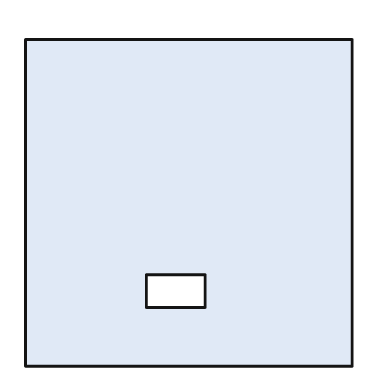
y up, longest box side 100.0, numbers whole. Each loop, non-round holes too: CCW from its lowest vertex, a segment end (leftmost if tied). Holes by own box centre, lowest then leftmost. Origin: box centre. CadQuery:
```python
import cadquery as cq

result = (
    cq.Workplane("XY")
    .moveTo(-50.0, -50.0)
    .lineTo(50.0, -50.0)
    .lineTo(50.0, 50.0)
    .lineTo(-50.0, 50.0)
    .close()
    .moveTo(-13.0, -32.0)
    .lineTo(5.0, -32.0)
    .lineTo(5.0, -22.0)
    .lineTo(-13.0, -22.0)
    .close()
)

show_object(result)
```